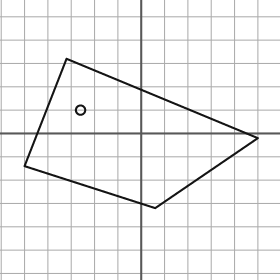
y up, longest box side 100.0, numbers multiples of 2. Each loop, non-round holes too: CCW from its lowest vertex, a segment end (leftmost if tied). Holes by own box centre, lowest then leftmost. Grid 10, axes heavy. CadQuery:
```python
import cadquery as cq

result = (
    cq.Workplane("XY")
    .moveTo(6.0, -32.0)
    .lineTo(50.0, -2.0)
    .lineTo(-32.0, 32.0)
    .lineTo(-50.0, -14.0)
    .close()
    .moveTo(-26.0, 10.0)
    .circle(2.0)
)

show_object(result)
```